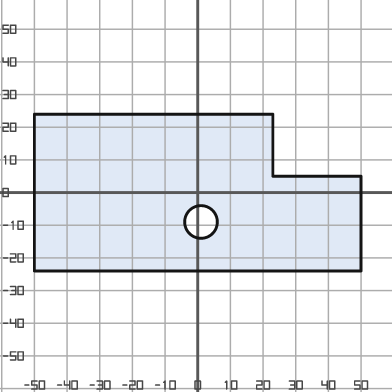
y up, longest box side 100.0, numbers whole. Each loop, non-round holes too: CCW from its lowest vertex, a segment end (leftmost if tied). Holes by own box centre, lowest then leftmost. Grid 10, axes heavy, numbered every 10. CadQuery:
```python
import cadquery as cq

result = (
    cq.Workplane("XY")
    .moveTo(-50.0, -24.0)
    .lineTo(50.0, -24.0)
    .lineTo(50.0, 5.0)
    .lineTo(23.0, 5.0)
    .lineTo(23.0, 24.0)
    .lineTo(-50.0, 24.0)
    .close()
    .moveTo(1.0, -9.0)
    .circle(5.0)
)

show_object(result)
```